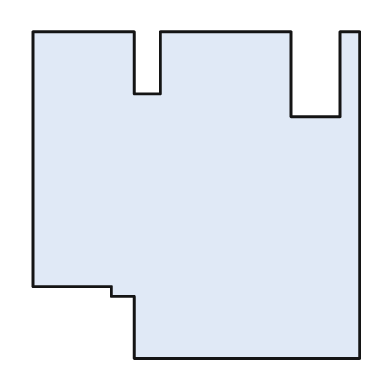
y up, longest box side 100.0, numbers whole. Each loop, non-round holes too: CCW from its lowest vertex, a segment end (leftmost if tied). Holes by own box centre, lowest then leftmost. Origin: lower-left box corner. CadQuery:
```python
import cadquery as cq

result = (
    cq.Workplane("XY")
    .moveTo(31.0, 0.0)
    .lineTo(100.0, 0.0)
    .lineTo(100.0, 100.0)
    .lineTo(94.0, 100.0)
    .lineTo(94.0, 74.0)
    .lineTo(79.0, 74.0)
    .lineTo(79.0, 100.0)
    .lineTo(39.0, 100.0)
    .lineTo(39.0, 81.0)
    .lineTo(31.0, 81.0)
    .lineTo(31.0, 100.0)
    .lineTo(0.0, 100.0)
    .lineTo(0.0, 22.0)
    .lineTo(24.0, 22.0)
    .lineTo(24.0, 19.0)
    .lineTo(31.0, 19.0)
    .close()
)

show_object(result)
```